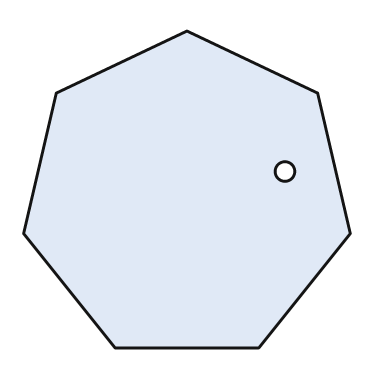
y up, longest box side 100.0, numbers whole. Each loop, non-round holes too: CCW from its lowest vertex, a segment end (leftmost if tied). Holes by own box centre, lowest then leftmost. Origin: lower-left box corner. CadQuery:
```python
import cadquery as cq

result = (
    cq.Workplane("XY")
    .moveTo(28.0, 0.0)
    .lineTo(72.0, 0.0)
    .lineTo(100.0, 35.0)
    .lineTo(90.0, 78.0)
    .lineTo(50.0, 97.0)
    .lineTo(10.0, 78.0)
    .lineTo(0.0, 35.0)
    .close()
    .moveTo(80.0, 54.0)
    .circle(3.0)
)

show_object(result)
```